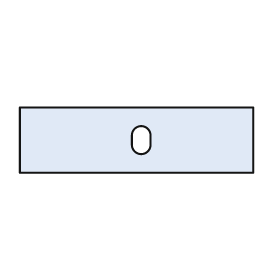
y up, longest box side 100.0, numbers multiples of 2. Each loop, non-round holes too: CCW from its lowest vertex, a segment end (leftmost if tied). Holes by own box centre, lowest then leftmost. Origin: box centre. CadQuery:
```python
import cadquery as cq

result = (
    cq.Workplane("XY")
    .moveTo(-50.0, -14.0)
    .lineTo(50.0, -14.0)
    .lineTo(50.0, 14.0)
    .lineTo(-50.0, 14.0)
    .close()
    .moveTo(-2.0, -2.0)
    .threePointArc((2.0, -6.0), (6.0, -2.0))
    .lineTo(6.0, 2.0)
    .threePointArc((2.0, 6.0), (-2.0, 2.0))
    .close()
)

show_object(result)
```